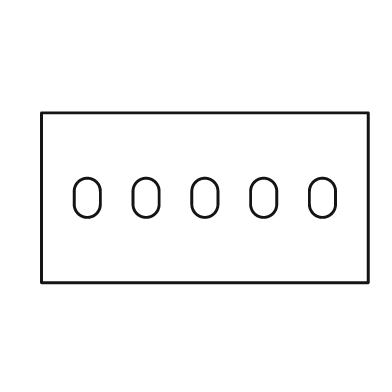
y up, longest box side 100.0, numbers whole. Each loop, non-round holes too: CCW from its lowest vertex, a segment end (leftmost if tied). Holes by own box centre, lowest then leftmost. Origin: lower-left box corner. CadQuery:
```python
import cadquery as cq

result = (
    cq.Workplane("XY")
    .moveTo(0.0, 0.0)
    .lineTo(100.0, 0.0)
    .lineTo(100.0, 52.0)
    .lineTo(0.0, 52.0)
    .close()
    .moveTo(10.0, 24.0)
    .threePointArc((14.0, 20.0), (18.0, 24.0))
    .lineTo(18.0, 28.0)
    .threePointArc((14.0, 32.0), (10.0, 28.0))
    .close()
    .moveTo(28.0, 24.0)
    .threePointArc((32.0, 20.0), (36.0, 24.0))
    .lineTo(36.0, 28.0)
    .threePointArc((32.0, 32.0), (28.0, 28.0))
    .close()
    .moveTo(46.0, 24.0)
    .threePointArc((50.0, 20.0), (54.0, 24.0))
    .lineTo(54.0, 28.0)
    .threePointArc((50.0, 32.0), (46.0, 28.0))
    .close()
    .moveTo(64.0, 24.0)
    .threePointArc((68.0, 20.0), (72.0, 24.0))
    .lineTo(72.0, 28.0)
    .threePointArc((68.0, 32.0), (64.0, 28.0))
    .close()
    .moveTo(82.0, 24.0)
    .threePointArc((86.0, 20.0), (90.0, 24.0))
    .lineTo(90.0, 28.0)
    .threePointArc((86.0, 32.0), (82.0, 28.0))
    .close()
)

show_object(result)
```